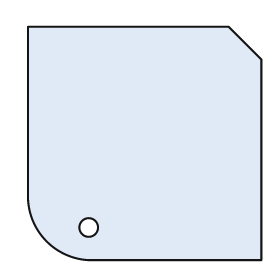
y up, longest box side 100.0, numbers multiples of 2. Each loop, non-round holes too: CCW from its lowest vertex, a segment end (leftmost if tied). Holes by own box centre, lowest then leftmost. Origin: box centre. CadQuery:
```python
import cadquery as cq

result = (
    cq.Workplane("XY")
    .moveTo(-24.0, -50.0)
    .lineTo(50.0, -50.0)
    .lineTo(50.0, 36.0)
    .lineTo(36.0, 50.0)
    .lineTo(-50.0, 50.0)
    .lineTo(-50.0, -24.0)
    .threePointArc((-42.0, -42.0), (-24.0, -50.0))
    .close()
    .moveTo(-24.0, -36.0)
    .circle(4.0)
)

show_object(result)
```